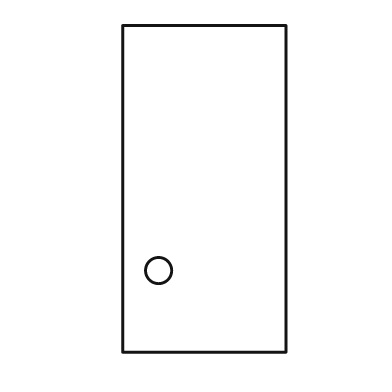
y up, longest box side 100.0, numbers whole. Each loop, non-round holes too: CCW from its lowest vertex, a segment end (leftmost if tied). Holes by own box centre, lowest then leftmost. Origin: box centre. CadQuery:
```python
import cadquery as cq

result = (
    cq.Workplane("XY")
    .moveTo(-25.0, -50.0)
    .lineTo(25.0, -50.0)
    .lineTo(25.0, 50.0)
    .lineTo(-25.0, 50.0)
    .close()
    .moveTo(-14.0, -25.0)
    .circle(4.0)
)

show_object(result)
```